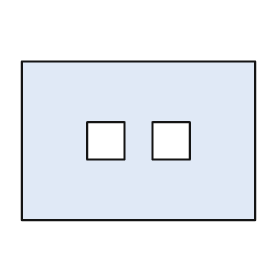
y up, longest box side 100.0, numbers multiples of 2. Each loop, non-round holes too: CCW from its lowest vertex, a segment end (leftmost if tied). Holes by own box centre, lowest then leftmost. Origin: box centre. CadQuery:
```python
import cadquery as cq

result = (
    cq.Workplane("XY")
    .moveTo(-50.0, -34.0)
    .lineTo(50.0, -34.0)
    .lineTo(50.0, 34.0)
    .lineTo(-50.0, 34.0)
    .close()
    .moveTo(-22.0, -8.0)
    .lineTo(-6.0, -8.0)
    .lineTo(-6.0, 8.0)
    .lineTo(-22.0, 8.0)
    .close()
    .moveTo(6.0, -8.0)
    .lineTo(22.0, -8.0)
    .lineTo(22.0, 8.0)
    .lineTo(6.0, 8.0)
    .close()
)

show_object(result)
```